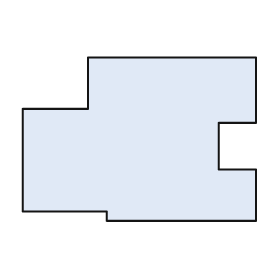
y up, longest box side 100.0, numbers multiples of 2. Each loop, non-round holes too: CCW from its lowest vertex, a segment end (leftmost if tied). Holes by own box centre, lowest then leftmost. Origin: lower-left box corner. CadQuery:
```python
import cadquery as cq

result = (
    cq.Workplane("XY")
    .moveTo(36.0, 0.0)
    .lineTo(100.0, 0.0)
    .lineTo(100.0, 22.0)
    .lineTo(84.0, 22.0)
    .lineTo(84.0, 42.0)
    .lineTo(100.0, 42.0)
    .lineTo(100.0, 70.0)
    .lineTo(28.0, 70.0)
    .lineTo(28.0, 48.0)
    .lineTo(0.0, 48.0)
    .lineTo(0.0, 4.0)
    .lineTo(36.0, 4.0)
    .close()
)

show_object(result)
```